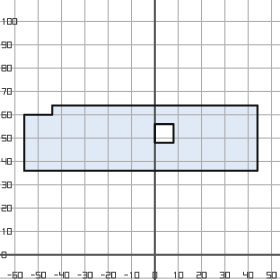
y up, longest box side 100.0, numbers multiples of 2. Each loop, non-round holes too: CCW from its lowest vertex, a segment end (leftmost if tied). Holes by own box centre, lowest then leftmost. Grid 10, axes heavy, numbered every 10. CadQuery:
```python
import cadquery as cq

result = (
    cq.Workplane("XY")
    .moveTo(-56.0, 36.0)
    .lineTo(44.0, 36.0)
    .lineTo(44.0, 64.0)
    .lineTo(-44.0, 64.0)
    .lineTo(-44.0, 60.0)
    .lineTo(-56.0, 60.0)
    .close()
    .moveTo(0.0, 48.0)
    .lineTo(8.0, 48.0)
    .lineTo(8.0, 56.0)
    .lineTo(0.0, 56.0)
    .close()
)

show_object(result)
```